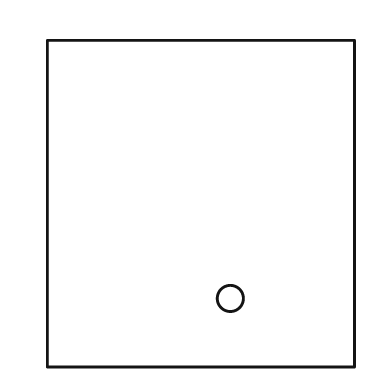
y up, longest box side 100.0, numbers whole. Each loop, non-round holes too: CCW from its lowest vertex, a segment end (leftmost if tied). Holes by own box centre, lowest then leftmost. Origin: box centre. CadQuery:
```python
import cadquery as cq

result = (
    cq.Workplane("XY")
    .moveTo(-47.0, -50.0)
    .lineTo(47.0, -50.0)
    .lineTo(47.0, 50.0)
    .lineTo(-47.0, 50.0)
    .close()
    .moveTo(9.0, -29.0)
    .circle(4.0)
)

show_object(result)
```